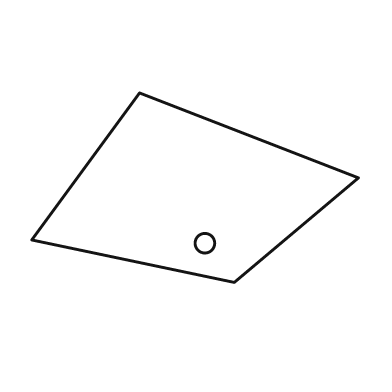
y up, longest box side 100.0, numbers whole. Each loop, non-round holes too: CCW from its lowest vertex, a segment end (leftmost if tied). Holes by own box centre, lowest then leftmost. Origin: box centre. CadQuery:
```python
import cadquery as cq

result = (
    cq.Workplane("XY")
    .moveTo(12.0, -29.0)
    .lineTo(50.0, 3.0)
    .lineTo(-17.0, 29.0)
    .lineTo(-50.0, -16.0)
    .close()
    .moveTo(3.0, -17.0)
    .circle(3.0)
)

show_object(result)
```